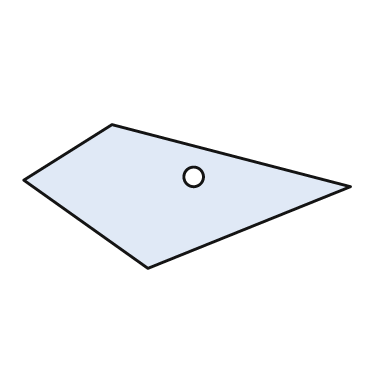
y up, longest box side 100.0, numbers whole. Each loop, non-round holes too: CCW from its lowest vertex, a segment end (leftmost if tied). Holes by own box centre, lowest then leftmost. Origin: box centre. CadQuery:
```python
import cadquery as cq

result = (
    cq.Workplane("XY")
    .moveTo(-12.0, -22.0)
    .lineTo(50.0, 3.0)
    .lineTo(-23.0, 22.0)
    .lineTo(-50.0, 5.0)
    .close()
    .moveTo(2.0, 6.0)
    .circle(3.0)
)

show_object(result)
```